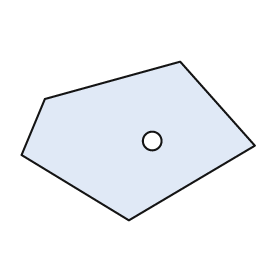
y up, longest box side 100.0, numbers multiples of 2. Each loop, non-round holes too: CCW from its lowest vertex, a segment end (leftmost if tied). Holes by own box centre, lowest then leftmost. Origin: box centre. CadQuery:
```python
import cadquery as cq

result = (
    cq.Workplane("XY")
    .moveTo(-4.0, -34.0)
    .lineTo(50.0, -2.0)
    .lineTo(18.0, 34.0)
    .lineTo(-40.0, 18.0)
    .lineTo(-50.0, -6.0)
    .close()
    .moveTo(6.0, 0.0)
    .circle(4.0)
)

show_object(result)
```